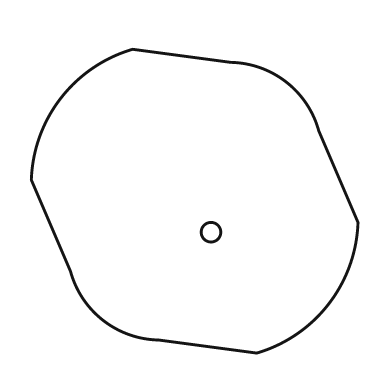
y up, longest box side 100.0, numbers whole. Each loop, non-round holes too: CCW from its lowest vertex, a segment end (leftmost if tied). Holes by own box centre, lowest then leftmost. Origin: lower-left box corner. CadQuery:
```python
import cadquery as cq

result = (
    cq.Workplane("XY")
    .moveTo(69.0, 0.0)
    .threePointArc((91.0, 15.0), (100.0, 40.0))
    .lineTo(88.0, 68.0)
    .threePointArc((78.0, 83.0), (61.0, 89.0))
    .lineTo(31.0, 93.0)
    .threePointArc((9.0, 78.0), (0.0, 53.0))
    .lineTo(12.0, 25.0)
    .threePointArc((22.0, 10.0), (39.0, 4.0))
    .close()
    .moveTo(55.0, 37.0)
    .circle(3.0)
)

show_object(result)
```